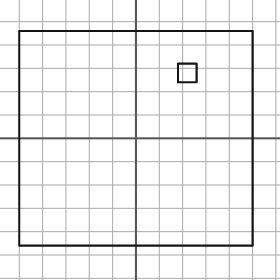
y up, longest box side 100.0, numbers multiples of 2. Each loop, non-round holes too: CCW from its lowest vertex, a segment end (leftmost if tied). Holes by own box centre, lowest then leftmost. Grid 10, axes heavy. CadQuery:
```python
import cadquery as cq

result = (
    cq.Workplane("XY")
    .moveTo(-50.0, -46.0)
    .lineTo(50.0, -46.0)
    .lineTo(50.0, 46.0)
    .lineTo(-50.0, 46.0)
    .close()
    .moveTo(18.0, 24.0)
    .lineTo(26.0, 24.0)
    .lineTo(26.0, 32.0)
    .lineTo(18.0, 32.0)
    .close()
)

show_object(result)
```